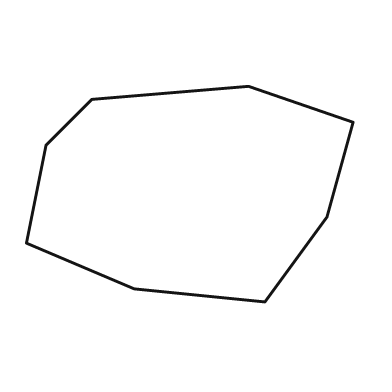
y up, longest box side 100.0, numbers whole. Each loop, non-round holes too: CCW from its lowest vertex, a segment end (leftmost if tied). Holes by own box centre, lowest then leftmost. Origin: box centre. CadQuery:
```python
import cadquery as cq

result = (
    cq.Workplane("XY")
    .moveTo(23.0, -33.0)
    .lineTo(42.0, -7.0)
    .lineTo(50.0, 22.0)
    .lineTo(18.0, 33.0)
    .lineTo(-30.0, 29.0)
    .lineTo(-44.0, 15.0)
    .lineTo(-50.0, -15.0)
    .lineTo(-17.0, -29.0)
    .close()
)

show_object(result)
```